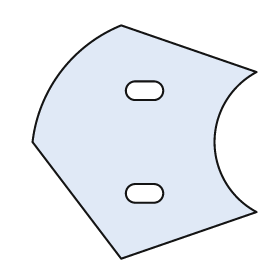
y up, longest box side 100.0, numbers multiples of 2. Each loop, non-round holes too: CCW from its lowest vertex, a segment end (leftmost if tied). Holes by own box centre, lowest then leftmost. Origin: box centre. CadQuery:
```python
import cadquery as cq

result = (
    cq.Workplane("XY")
    .moveTo(-10.0, -50.0)
    .lineTo(48.0, -30.0)
    .threePointArc((30.0, 0.0), (48.0, 30.0))
    .lineTo(-10.0, 50.0)
    .threePointArc((-36.0, 30.0), (-48.0, 0.0))
    .close()
    .moveTo(-4.0, -26.0)
    .lineTo(4.0, -26.0)
    .threePointArc((8.0, -22.0), (4.0, -18.0))
    .lineTo(-4.0, -18.0)
    .threePointArc((-8.0, -22.0), (-4.0, -26.0))
    .close()
    .moveTo(-4.0, 18.0)
    .lineTo(4.0, 18.0)
    .threePointArc((8.0, 22.0), (4.0, 26.0))
    .lineTo(-4.0, 26.0)
    .threePointArc((-8.0, 22.0), (-4.0, 18.0))
    .close()
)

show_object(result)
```